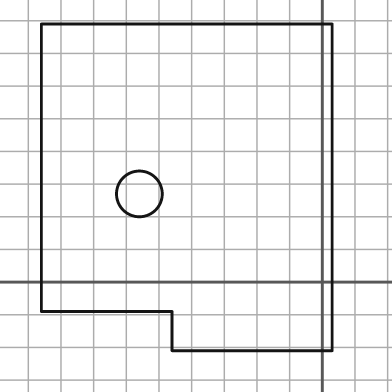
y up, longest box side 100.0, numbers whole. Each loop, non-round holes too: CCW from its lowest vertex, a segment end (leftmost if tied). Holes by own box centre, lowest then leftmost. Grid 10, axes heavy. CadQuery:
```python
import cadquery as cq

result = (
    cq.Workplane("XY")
    .moveTo(-46.0, -21.0)
    .lineTo(3.0, -21.0)
    .lineTo(3.0, 79.0)
    .lineTo(-86.0, 79.0)
    .lineTo(-86.0, -9.0)
    .lineTo(-46.0, -9.0)
    .close()
    .moveTo(-56.0, 27.0)
    .circle(7.0)
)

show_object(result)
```